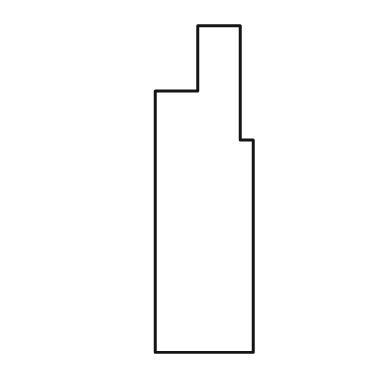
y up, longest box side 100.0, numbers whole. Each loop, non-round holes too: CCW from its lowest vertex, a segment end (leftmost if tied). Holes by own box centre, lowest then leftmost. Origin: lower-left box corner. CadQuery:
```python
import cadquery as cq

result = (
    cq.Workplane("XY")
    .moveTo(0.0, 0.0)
    .lineTo(30.0, 0.0)
    .lineTo(30.0, 65.0)
    .lineTo(26.0, 65.0)
    .lineTo(26.0, 100.0)
    .lineTo(13.0, 100.0)
    .lineTo(13.0, 80.0)
    .lineTo(0.0, 80.0)
    .close()
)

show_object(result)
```